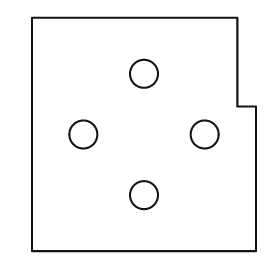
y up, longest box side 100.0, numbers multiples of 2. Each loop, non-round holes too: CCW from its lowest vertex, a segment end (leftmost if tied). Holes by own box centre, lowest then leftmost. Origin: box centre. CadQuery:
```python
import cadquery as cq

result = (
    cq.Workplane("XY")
    .moveTo(-48.0, -50.0)
    .lineTo(48.0, -50.0)
    .lineTo(48.0, 12.0)
    .lineTo(40.0, 12.0)
    .lineTo(40.0, 50.0)
    .lineTo(-48.0, 50.0)
    .close()
    .moveTo(0.0, -26.0)
    .circle(6.0)
    .moveTo(-26.0, 0.0)
    .circle(6.0)
    .moveTo(26.0, 0.0)
    .circle(6.0)
    .moveTo(0.0, 26.0)
    .circle(6.0)
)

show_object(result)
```